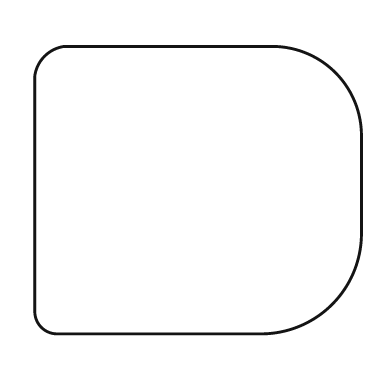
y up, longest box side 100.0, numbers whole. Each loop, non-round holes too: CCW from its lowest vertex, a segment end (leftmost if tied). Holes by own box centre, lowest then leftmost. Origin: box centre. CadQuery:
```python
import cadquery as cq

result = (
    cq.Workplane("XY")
    .moveTo(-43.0, -44.0)
    .lineTo(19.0, -44.0)
    .threePointArc((41.0, -35.0), (50.0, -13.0))
    .lineTo(50.0, 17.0)
    .threePointArc((42.0, 36.0), (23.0, 44.0))
    .lineTo(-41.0, 44.0)
    .threePointArc((-47.0, 41.0), (-50.0, 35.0))
    .lineTo(-50.0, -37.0)
    .threePointArc((-48.0, -42.0), (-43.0, -44.0))
    .close()
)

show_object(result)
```